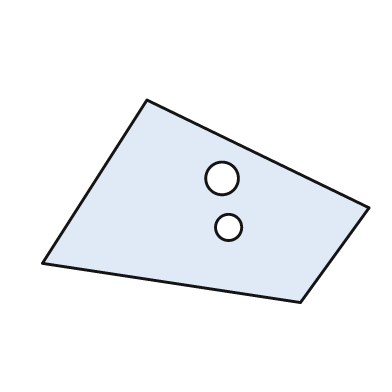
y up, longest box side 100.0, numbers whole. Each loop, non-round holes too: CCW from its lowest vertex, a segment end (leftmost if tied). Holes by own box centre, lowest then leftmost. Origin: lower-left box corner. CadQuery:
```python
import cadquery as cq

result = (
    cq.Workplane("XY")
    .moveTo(79.0, 0.0)
    .lineTo(100.0, 29.0)
    .lineTo(32.0, 62.0)
    .lineTo(0.0, 12.0)
    .close()
    .moveTo(57.0, 23.0)
    .circle(4.0)
    .moveTo(55.0, 38.0)
    .circle(5.0)
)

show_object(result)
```